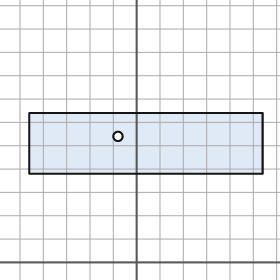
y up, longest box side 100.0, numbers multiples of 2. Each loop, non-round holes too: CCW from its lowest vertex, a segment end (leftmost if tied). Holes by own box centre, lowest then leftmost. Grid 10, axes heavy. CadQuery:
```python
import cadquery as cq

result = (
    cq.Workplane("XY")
    .moveTo(-46.0, 38.0)
    .lineTo(54.0, 38.0)
    .lineTo(54.0, 64.0)
    .lineTo(-46.0, 64.0)
    .close()
    .moveTo(-8.0, 54.0)
    .circle(2.0)
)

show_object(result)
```